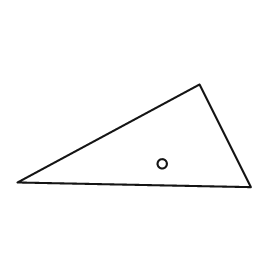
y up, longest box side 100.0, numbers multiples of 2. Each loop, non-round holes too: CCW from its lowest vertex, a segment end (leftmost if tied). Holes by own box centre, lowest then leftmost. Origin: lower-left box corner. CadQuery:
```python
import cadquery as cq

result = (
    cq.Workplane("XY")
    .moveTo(100.0, 0.0)
    .lineTo(78.0, 44.0)
    .lineTo(0.0, 2.0)
    .close()
    .moveTo(62.0, 10.0)
    .circle(2.0)
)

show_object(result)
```